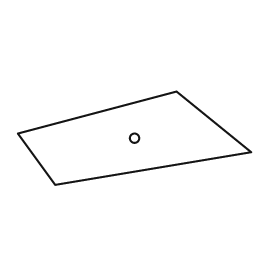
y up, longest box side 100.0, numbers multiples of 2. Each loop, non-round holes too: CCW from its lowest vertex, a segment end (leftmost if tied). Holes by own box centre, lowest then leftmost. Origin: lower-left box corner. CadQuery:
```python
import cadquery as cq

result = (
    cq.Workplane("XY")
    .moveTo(16.0, 0.0)
    .lineTo(100.0, 14.0)
    .lineTo(68.0, 40.0)
    .lineTo(0.0, 22.0)
    .close()
    .moveTo(50.0, 20.0)
    .circle(2.0)
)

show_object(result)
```